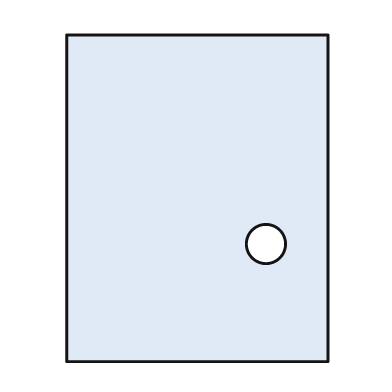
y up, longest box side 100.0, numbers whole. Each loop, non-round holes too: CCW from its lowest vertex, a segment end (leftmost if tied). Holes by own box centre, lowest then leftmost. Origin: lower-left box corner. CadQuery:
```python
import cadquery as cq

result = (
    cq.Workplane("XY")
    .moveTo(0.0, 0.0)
    .lineTo(80.0, 0.0)
    .lineTo(80.0, 100.0)
    .lineTo(0.0, 100.0)
    .close()
    .moveTo(61.0, 36.0)
    .circle(6.0)
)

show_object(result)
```